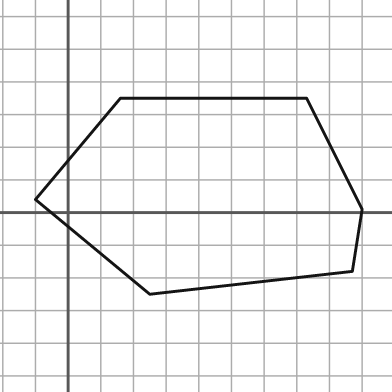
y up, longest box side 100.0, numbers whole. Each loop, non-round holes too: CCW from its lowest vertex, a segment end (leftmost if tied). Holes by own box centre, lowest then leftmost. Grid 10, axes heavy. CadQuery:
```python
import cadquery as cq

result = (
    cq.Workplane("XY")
    .moveTo(25.0, -25.0)
    .lineTo(87.0, -18.0)
    .lineTo(90.0, 1.0)
    .lineTo(73.0, 35.0)
    .lineTo(16.0, 35.0)
    .lineTo(-10.0, 4.0)
    .close()
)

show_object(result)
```